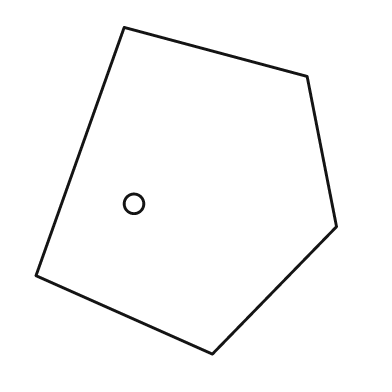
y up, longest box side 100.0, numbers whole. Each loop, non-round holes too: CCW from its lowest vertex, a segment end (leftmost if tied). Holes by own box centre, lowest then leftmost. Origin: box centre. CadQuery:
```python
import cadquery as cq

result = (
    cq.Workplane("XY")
    .moveTo(8.0, -50.0)
    .lineTo(46.0, -11.0)
    .lineTo(37.0, 35.0)
    .lineTo(-19.0, 50.0)
    .lineTo(-46.0, -26.0)
    .close()
    .moveTo(-16.0, -4.0)
    .circle(3.0)
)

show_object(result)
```